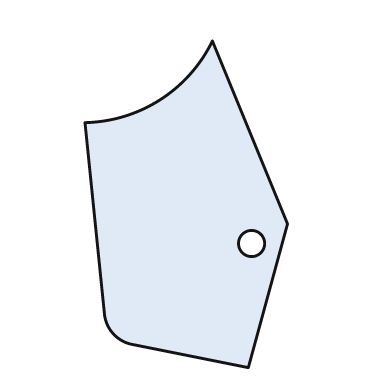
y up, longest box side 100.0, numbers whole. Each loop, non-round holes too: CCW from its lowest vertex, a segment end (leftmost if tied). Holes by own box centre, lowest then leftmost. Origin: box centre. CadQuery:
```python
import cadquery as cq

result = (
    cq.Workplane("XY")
    .moveTo(19.0, -50.0)
    .lineTo(31.0, -6.0)
    .lineTo(8.0, 50.0)
    .threePointArc((-8.0, 32.0), (-31.0, 25.0))
    .lineTo(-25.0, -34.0)
    .threePointArc((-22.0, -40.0), (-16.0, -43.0))
    .close()
    .moveTo(20.0, -12.0)
    .circle(4.0)
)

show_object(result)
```